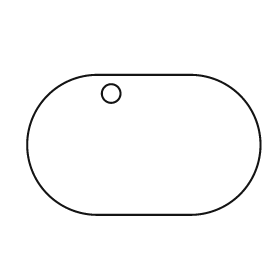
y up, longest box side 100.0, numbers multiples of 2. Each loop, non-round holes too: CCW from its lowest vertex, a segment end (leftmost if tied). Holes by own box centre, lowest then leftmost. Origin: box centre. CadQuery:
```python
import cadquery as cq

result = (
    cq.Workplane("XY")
    .moveTo(-20.0, -30.0)
    .lineTo(20.0, -30.0)
    .threePointArc((50.0, 0.0), (20.0, 30.0))
    .lineTo(-20.0, 30.0)
    .threePointArc((-50.0, 0.0), (-20.0, -30.0))
    .close()
    .moveTo(-14.0, 22.0)
    .circle(4.0)
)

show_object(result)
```